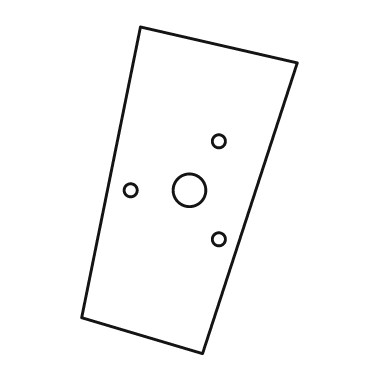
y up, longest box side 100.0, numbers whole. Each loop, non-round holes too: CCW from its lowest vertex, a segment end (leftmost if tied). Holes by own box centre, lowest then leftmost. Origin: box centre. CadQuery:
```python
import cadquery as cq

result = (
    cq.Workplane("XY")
    .moveTo(4.0, -50.0)
    .lineTo(33.0, 39.0)
    .lineTo(-15.0, 50.0)
    .lineTo(-33.0, -39.0)
    .close()
    .moveTo(9.0, -15.0)
    .circle(2.0)
    .moveTo(-18.0, 0.0)
    .circle(2.0)
    .moveTo(0.0, 0.0)
    .circle(5.0)
    .moveTo(9.0, 15.0)
    .circle(2.0)
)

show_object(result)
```